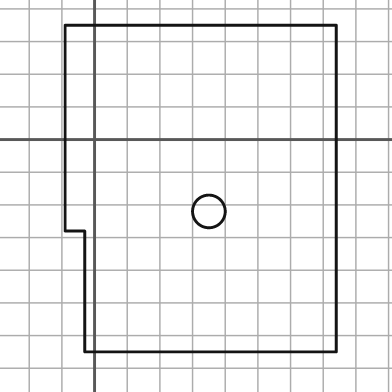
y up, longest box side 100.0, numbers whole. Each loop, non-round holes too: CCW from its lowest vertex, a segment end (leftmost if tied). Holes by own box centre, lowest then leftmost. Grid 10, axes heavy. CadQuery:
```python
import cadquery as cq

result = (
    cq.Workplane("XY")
    .moveTo(-3.0, -65.0)
    .lineTo(74.0, -65.0)
    .lineTo(74.0, 35.0)
    .lineTo(-9.0, 35.0)
    .lineTo(-9.0, -28.0)
    .lineTo(-3.0, -28.0)
    .close()
    .moveTo(35.0, -22.0)
    .circle(5.0)
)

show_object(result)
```